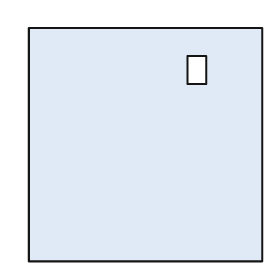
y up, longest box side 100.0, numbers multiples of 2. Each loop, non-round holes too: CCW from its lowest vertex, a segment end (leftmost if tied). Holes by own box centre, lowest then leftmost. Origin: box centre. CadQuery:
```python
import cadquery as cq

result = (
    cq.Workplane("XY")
    .moveTo(-50.0, -50.0)
    .lineTo(50.0, -50.0)
    .lineTo(50.0, 50.0)
    .lineTo(-50.0, 50.0)
    .close()
    .moveTo(18.0, 26.0)
    .lineTo(26.0, 26.0)
    .lineTo(26.0, 38.0)
    .lineTo(18.0, 38.0)
    .close()
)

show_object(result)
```